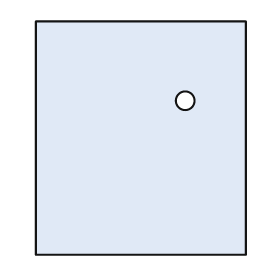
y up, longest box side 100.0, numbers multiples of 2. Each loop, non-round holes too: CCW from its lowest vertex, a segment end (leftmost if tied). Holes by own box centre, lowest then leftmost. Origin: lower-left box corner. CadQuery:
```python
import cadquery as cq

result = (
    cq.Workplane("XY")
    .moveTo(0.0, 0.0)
    .lineTo(90.0, 0.0)
    .lineTo(90.0, 100.0)
    .lineTo(0.0, 100.0)
    .close()
    .moveTo(64.0, 66.0)
    .circle(4.0)
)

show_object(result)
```